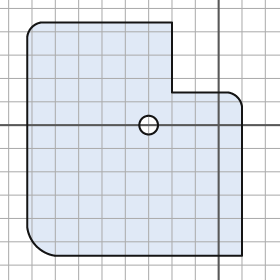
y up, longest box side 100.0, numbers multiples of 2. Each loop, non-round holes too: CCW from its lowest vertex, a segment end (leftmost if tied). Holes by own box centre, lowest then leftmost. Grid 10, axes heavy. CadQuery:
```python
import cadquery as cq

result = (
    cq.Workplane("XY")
    .moveTo(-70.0, -56.0)
    .lineTo(10.0, -56.0)
    .lineTo(10.0, 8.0)
    .threePointArc((8.0, 12.0), (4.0, 14.0))
    .lineTo(-20.0, 14.0)
    .lineTo(-20.0, 44.0)
    .lineTo(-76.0, 44.0)
    .threePointArc((-80.0, 42.0), (-82.0, 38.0))
    .lineTo(-82.0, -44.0)
    .threePointArc((-78.0, -52.0), (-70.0, -56.0))
    .close()
    .moveTo(-30.0, 0.0)
    .circle(4.0)
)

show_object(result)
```